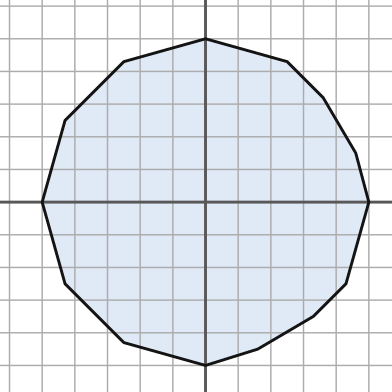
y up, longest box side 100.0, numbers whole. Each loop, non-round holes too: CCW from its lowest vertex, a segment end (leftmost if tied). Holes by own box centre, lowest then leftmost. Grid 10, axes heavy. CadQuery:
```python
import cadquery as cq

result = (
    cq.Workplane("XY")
    .moveTo(0.0, -50.0)
    .lineTo(16.0, -45.0)
    .lineTo(33.0, -35.0)
    .lineTo(43.0, -25.0)
    .lineTo(50.0, 0.0)
    .lineTo(46.0, 15.0)
    .lineTo(36.0, 32.0)
    .lineTo(25.0, 43.0)
    .lineTo(0.0, 50.0)
    .lineTo(-25.0, 43.0)
    .lineTo(-43.0, 25.0)
    .lineTo(-50.0, 0.0)
    .lineTo(-43.0, -25.0)
    .lineTo(-25.0, -43.0)
    .close()
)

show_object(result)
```